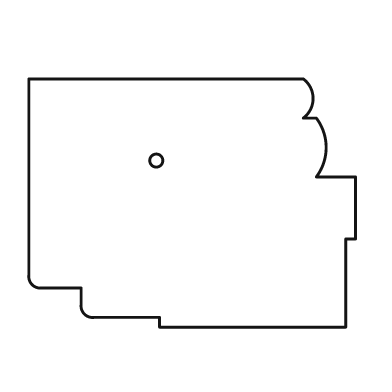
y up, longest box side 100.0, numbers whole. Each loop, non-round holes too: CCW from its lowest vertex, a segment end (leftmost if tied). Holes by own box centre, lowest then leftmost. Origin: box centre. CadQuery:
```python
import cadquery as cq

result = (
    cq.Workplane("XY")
    .moveTo(-10.0, -38.0)
    .lineTo(47.0, -38.0)
    .lineTo(47.0, -11.0)
    .lineTo(50.0, -11.0)
    .lineTo(50.0, 8.0)
    .lineTo(38.0, 8.0)
    .threePointArc((41.0, 17.0), (38.0, 26.0))
    .lineTo(34.0, 26.0)
    .threePointArc((37.0, 32.0), (34.0, 38.0))
    .lineTo(-50.0, 38.0)
    .lineTo(-50.0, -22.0)
    .threePointArc((-49.0, -25.0), (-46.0, -26.0))
    .lineTo(-34.0, -26.0)
    .lineTo(-34.0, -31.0)
    .threePointArc((-33.0, -34.0), (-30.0, -35.0))
    .lineTo(-10.0, -35.0)
    .close()
    .moveTo(-11.0, 13.0)
    .circle(2.0)
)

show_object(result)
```